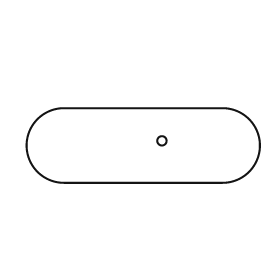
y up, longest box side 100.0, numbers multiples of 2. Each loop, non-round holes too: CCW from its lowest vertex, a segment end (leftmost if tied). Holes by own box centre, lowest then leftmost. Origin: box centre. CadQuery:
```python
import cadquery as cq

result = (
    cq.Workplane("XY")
    .moveTo(-34.0, -16.0)
    .lineTo(34.0, -16.0)
    .threePointArc((50.0, 0.0), (34.0, 16.0))
    .lineTo(-34.0, 16.0)
    .threePointArc((-50.0, 0.0), (-34.0, -16.0))
    .close()
    .moveTo(8.0, 2.0)
    .circle(2.0)
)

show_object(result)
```